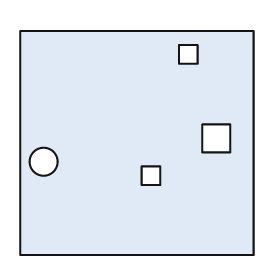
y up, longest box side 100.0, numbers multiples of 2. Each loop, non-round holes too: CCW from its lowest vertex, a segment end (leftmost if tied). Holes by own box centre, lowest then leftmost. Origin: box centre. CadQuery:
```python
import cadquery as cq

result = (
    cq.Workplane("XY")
    .moveTo(-50.0, -48.0)
    .lineTo(50.0, -48.0)
    .lineTo(50.0, 48.0)
    .lineTo(-50.0, 48.0)
    .close()
    .moveTo(2.0, -18.0)
    .lineTo(10.0, -18.0)
    .lineTo(10.0, -10.0)
    .lineTo(2.0, -10.0)
    .close()
    .moveTo(-40.0, -8.0)
    .circle(6.0)
    .moveTo(28.0, -4.0)
    .lineTo(40.0, -4.0)
    .lineTo(40.0, 8.0)
    .lineTo(28.0, 8.0)
    .close()
    .moveTo(18.0, 34.0)
    .lineTo(26.0, 34.0)
    .lineTo(26.0, 42.0)
    .lineTo(18.0, 42.0)
    .close()
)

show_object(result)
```